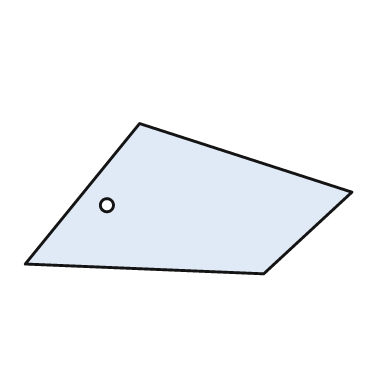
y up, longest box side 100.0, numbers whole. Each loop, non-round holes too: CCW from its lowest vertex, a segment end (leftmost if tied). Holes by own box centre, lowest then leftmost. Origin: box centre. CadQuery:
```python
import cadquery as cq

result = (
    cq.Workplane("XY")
    .moveTo(23.0, -23.0)
    .lineTo(50.0, 2.0)
    .lineTo(-15.0, 23.0)
    .lineTo(-50.0, -20.0)
    .close()
    .moveTo(-25.0, -2.0)
    .circle(2.0)
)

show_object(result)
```